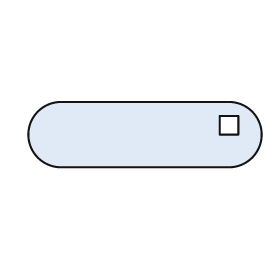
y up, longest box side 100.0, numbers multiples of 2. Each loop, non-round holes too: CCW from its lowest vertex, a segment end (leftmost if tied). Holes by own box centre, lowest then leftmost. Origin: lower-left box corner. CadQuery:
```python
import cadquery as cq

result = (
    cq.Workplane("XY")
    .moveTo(14.0, 0.0)
    .lineTo(86.0, 0.0)
    .threePointArc((100.0, 14.0), (86.0, 28.0))
    .lineTo(14.0, 28.0)
    .threePointArc((0.0, 14.0), (14.0, 0.0))
    .close()
    .moveTo(82.0, 14.0)
    .lineTo(90.0, 14.0)
    .lineTo(90.0, 22.0)
    .lineTo(82.0, 22.0)
    .close()
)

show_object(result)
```